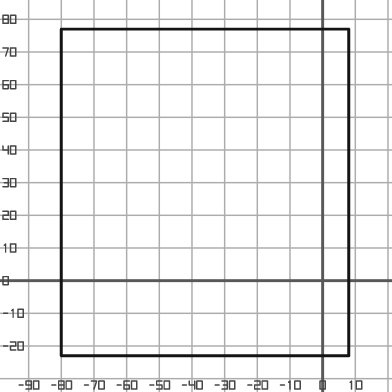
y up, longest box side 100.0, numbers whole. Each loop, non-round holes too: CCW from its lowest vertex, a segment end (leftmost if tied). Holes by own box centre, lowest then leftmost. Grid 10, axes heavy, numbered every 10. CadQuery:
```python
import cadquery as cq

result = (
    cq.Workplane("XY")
    .moveTo(-80.0, -23.0)
    .lineTo(8.0, -23.0)
    .lineTo(8.0, 77.0)
    .lineTo(-80.0, 77.0)
    .close()
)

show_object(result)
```